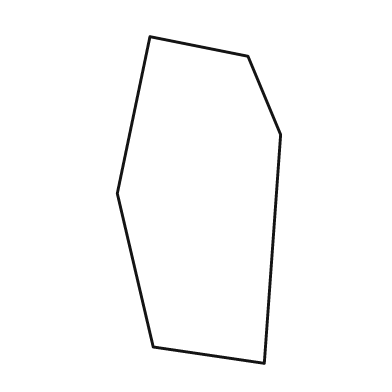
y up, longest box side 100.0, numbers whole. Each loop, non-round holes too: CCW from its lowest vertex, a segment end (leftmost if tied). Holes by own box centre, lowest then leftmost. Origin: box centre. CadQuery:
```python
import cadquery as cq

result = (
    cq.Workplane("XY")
    .moveTo(20.0, -50.0)
    .lineTo(25.0, 20.0)
    .lineTo(15.0, 44.0)
    .lineTo(-15.0, 50.0)
    .lineTo(-25.0, 2.0)
    .lineTo(-14.0, -45.0)
    .close()
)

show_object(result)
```